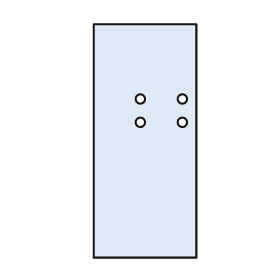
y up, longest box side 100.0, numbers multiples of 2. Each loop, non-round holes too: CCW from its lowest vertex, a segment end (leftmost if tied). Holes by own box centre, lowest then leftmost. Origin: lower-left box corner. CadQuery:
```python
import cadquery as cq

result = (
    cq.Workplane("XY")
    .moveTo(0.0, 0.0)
    .lineTo(44.0, 0.0)
    .lineTo(44.0, 100.0)
    .lineTo(0.0, 100.0)
    .close()
    .moveTo(20.0, 58.0)
    .circle(2.0)
    .moveTo(38.0, 58.0)
    .circle(2.0)
    .moveTo(20.0, 68.0)
    .circle(2.0)
    .moveTo(38.0, 68.0)
    .circle(2.0)
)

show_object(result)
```